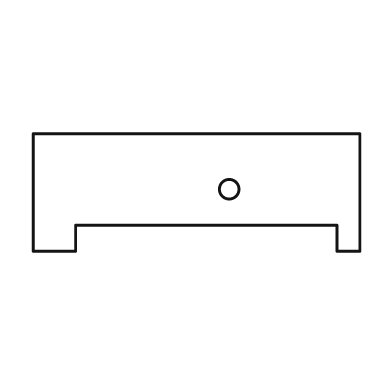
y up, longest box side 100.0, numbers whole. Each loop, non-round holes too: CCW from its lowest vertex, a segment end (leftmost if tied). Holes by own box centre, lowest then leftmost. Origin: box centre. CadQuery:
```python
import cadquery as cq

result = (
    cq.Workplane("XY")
    .moveTo(-50.0, -18.0)
    .lineTo(-37.0, -18.0)
    .lineTo(-37.0, -10.0)
    .lineTo(43.0, -10.0)
    .lineTo(43.0, -18.0)
    .lineTo(50.0, -18.0)
    .lineTo(50.0, 18.0)
    .lineTo(-50.0, 18.0)
    .close()
    .moveTo(10.0, 1.0)
    .circle(3.0)
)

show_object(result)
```